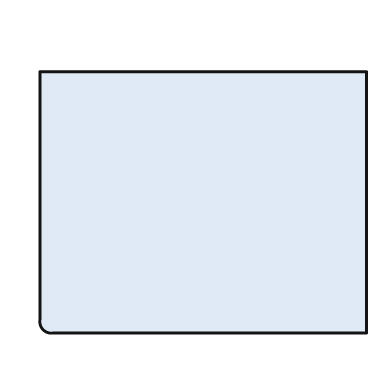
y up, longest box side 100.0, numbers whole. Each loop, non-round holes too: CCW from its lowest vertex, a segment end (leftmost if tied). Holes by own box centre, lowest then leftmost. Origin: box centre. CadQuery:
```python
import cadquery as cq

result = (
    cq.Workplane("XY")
    .moveTo(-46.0, -40.0)
    .lineTo(50.0, -40.0)
    .lineTo(50.0, 40.0)
    .lineTo(-50.0, 40.0)
    .lineTo(-50.0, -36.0)
    .threePointArc((-49.0, -39.0), (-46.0, -40.0))
    .close()
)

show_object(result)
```